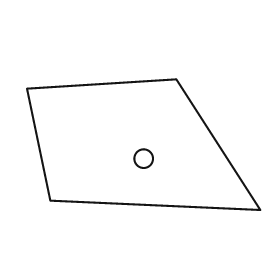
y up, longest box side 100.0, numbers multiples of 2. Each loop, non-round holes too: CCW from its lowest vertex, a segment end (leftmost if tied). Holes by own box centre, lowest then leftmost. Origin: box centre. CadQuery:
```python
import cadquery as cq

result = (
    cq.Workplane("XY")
    .moveTo(50.0, -28.0)
    .lineTo(14.0, 28.0)
    .lineTo(-50.0, 24.0)
    .lineTo(-40.0, -24.0)
    .close()
    .moveTo(0.0, -6.0)
    .circle(4.0)
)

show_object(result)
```